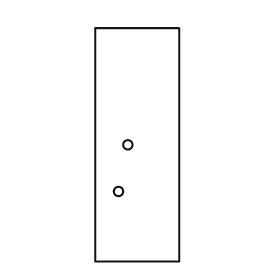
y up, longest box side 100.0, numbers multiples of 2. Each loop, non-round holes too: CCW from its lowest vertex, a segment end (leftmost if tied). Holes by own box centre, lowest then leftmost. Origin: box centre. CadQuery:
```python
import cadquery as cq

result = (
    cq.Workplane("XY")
    .moveTo(-18.0, -50.0)
    .lineTo(18.0, -50.0)
    .lineTo(18.0, 50.0)
    .lineTo(-18.0, 50.0)
    .close()
    .moveTo(-8.0, -20.0)
    .circle(2.0)
    .moveTo(-4.0, 0.0)
    .circle(2.0)
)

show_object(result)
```